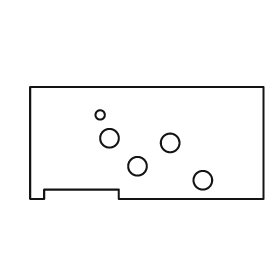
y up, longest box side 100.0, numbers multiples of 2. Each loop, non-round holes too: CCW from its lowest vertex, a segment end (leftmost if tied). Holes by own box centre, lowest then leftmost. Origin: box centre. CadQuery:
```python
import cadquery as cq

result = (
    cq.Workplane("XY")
    .moveTo(-50.0, -24.0)
    .lineTo(-44.0, -24.0)
    .lineTo(-44.0, -20.0)
    .lineTo(-12.0, -20.0)
    .lineTo(-12.0, -24.0)
    .lineTo(50.0, -24.0)
    .lineTo(50.0, 24.0)
    .lineTo(-50.0, 24.0)
    .close()
    .moveTo(24.0, -16.0)
    .circle(4.0)
    .moveTo(-4.0, -10.0)
    .circle(4.0)
    .moveTo(10.0, 0.0)
    .circle(4.0)
    .moveTo(-16.0, 2.0)
    .circle(4.0)
    .moveTo(-20.0, 12.0)
    .circle(2.0)
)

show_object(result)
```